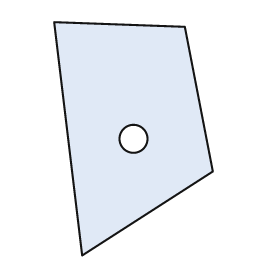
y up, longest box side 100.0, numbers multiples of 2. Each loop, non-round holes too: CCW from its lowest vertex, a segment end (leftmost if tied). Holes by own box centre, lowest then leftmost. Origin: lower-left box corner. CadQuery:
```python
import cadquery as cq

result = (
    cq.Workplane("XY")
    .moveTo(12.0, 0.0)
    .lineTo(68.0, 36.0)
    .lineTo(56.0, 98.0)
    .lineTo(0.0, 100.0)
    .close()
    .moveTo(34.0, 50.0)
    .circle(6.0)
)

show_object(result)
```